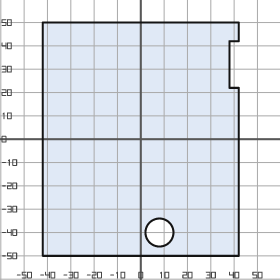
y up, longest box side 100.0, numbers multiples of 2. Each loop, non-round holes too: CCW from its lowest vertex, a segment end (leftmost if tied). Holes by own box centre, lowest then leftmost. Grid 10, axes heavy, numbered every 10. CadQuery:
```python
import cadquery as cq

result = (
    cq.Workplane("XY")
    .moveTo(-42.0, -50.0)
    .lineTo(42.0, -50.0)
    .lineTo(42.0, 22.0)
    .lineTo(38.0, 22.0)
    .lineTo(38.0, 42.0)
    .lineTo(42.0, 42.0)
    .lineTo(42.0, 50.0)
    .lineTo(-42.0, 50.0)
    .close()
    .moveTo(8.0, -40.0)
    .circle(6.0)
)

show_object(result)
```